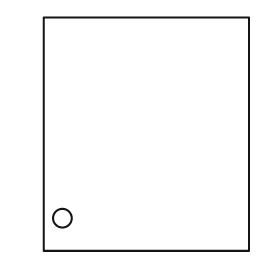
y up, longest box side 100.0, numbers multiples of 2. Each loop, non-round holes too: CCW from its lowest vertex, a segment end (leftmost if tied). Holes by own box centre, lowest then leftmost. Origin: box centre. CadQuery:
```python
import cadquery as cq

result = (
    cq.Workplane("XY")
    .moveTo(-44.0, -50.0)
    .lineTo(44.0, -50.0)
    .lineTo(44.0, 50.0)
    .lineTo(-44.0, 50.0)
    .close()
    .moveTo(-36.0, -36.0)
    .circle(4.0)
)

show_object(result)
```